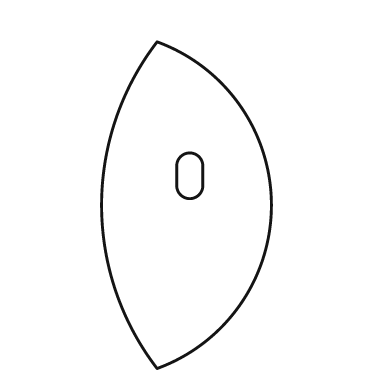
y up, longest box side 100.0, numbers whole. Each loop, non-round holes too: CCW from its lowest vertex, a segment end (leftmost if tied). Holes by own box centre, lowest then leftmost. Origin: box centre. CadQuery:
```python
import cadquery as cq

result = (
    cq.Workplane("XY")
    .moveTo(-9.0, -50.0)
    .threePointArc((26.0, 0.0), (-9.0, 50.0))
    .threePointArc((-26.0, 0.0), (-9.0, -50.0))
    .close()
    .moveTo(-3.0, 6.0)
    .threePointArc((1.0, 2.0), (5.0, 6.0))
    .lineTo(5.0, 12.0)
    .threePointArc((1.0, 16.0), (-3.0, 12.0))
    .close()
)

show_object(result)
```